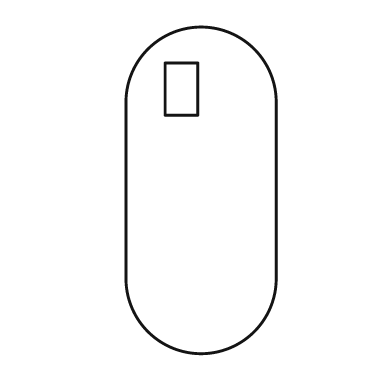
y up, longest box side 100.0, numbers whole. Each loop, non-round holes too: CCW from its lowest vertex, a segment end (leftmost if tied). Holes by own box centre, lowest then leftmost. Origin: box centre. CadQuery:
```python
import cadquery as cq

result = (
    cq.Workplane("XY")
    .moveTo(-23.0, -27.0)
    .threePointArc((0.0, -50.0), (23.0, -27.0))
    .lineTo(23.0, 27.0)
    .threePointArc((0.0, 50.0), (-23.0, 27.0))
    .close()
    .moveTo(-11.0, 23.0)
    .lineTo(-1.0, 23.0)
    .lineTo(-1.0, 39.0)
    .lineTo(-11.0, 39.0)
    .close()
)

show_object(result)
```